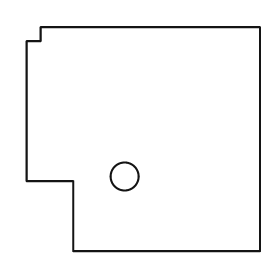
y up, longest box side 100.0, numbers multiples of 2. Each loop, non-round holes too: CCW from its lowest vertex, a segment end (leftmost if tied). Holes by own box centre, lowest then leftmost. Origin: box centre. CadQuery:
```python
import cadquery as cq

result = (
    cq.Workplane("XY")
    .moveTo(-30.0, -48.0)
    .lineTo(50.0, -48.0)
    .lineTo(50.0, 48.0)
    .lineTo(-44.0, 48.0)
    .lineTo(-44.0, 42.0)
    .lineTo(-50.0, 42.0)
    .lineTo(-50.0, -18.0)
    .lineTo(-30.0, -18.0)
    .close()
    .moveTo(-8.0, -16.0)
    .circle(6.0)
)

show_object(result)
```